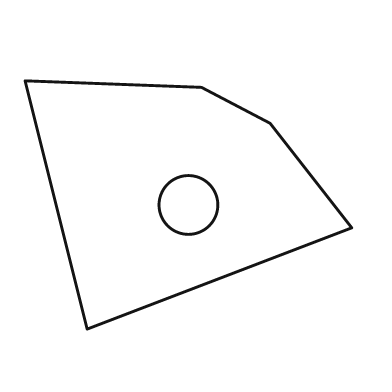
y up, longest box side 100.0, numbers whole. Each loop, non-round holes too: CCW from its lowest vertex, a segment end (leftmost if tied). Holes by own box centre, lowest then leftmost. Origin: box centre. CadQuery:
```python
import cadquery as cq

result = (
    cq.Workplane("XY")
    .moveTo(-31.0, -38.0)
    .lineTo(50.0, -7.0)
    .lineTo(25.0, 25.0)
    .lineTo(4.0, 36.0)
    .lineTo(-50.0, 38.0)
    .close()
    .moveTo(0.0, 0.0)
    .circle(9.0)
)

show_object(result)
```